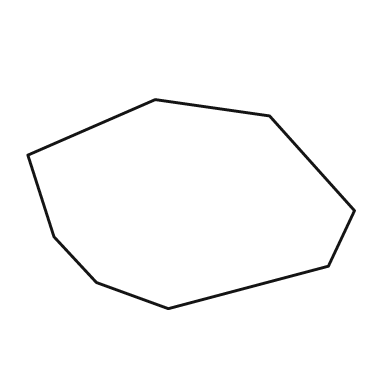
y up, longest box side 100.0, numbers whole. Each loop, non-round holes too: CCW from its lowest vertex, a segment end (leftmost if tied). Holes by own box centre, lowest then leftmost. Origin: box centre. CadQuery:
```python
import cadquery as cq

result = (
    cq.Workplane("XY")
    .moveTo(-7.0, -32.0)
    .lineTo(42.0, -19.0)
    .lineTo(50.0, -2.0)
    .lineTo(24.0, 27.0)
    .lineTo(-11.0, 32.0)
    .lineTo(-50.0, 15.0)
    .lineTo(-42.0, -10.0)
    .lineTo(-29.0, -24.0)
    .close()
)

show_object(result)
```